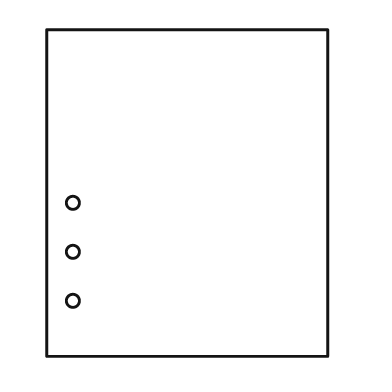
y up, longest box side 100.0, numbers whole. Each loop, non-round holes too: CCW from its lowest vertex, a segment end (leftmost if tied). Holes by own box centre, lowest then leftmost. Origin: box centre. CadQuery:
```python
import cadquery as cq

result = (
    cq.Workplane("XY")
    .moveTo(-43.0, -50.0)
    .lineTo(43.0, -50.0)
    .lineTo(43.0, 50.0)
    .lineTo(-43.0, 50.0)
    .close()
    .moveTo(-35.0, -33.0)
    .circle(2.0)
    .moveTo(-35.0, -18.0)
    .circle(2.0)
    .moveTo(-35.0, -3.0)
    .circle(2.0)
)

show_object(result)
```